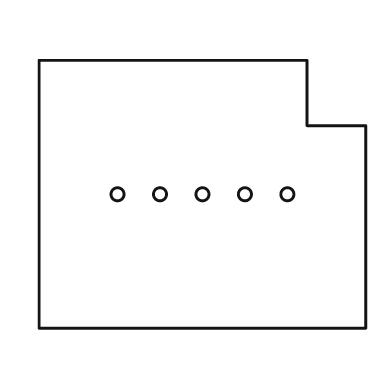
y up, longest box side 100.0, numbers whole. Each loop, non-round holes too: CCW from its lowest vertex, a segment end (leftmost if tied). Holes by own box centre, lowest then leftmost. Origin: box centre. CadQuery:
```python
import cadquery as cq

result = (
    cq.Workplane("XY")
    .moveTo(-50.0, -41.0)
    .lineTo(50.0, -41.0)
    .lineTo(50.0, 21.0)
    .lineTo(32.0, 21.0)
    .lineTo(32.0, 41.0)
    .lineTo(-50.0, 41.0)
    .close()
    .moveTo(-26.0, 0.0)
    .circle(2.0)
    .moveTo(-13.0, 0.0)
    .circle(2.0)
    .moveTo(0.0, 0.0)
    .circle(2.0)
    .moveTo(13.0, 0.0)
    .circle(2.0)
    .moveTo(26.0, 0.0)
    .circle(2.0)
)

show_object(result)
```